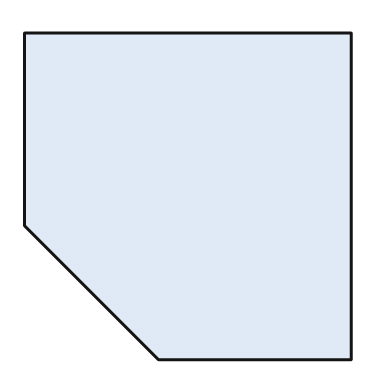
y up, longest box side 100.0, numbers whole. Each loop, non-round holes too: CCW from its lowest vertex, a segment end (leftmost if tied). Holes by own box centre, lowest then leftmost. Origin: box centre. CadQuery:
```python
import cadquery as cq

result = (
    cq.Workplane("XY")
    .moveTo(-9.0, -50.0)
    .lineTo(50.0, -50.0)
    .lineTo(50.0, 50.0)
    .lineTo(-50.0, 50.0)
    .lineTo(-50.0, -9.0)
    .close()
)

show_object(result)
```